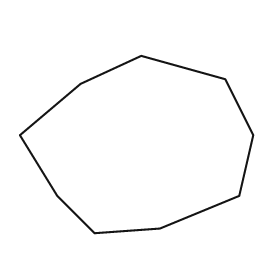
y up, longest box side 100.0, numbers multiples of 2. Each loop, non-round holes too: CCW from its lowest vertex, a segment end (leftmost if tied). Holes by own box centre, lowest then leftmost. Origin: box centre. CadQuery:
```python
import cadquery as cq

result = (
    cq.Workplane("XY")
    .moveTo(-18.0, -38.0)
    .lineTo(10.0, -36.0)
    .lineTo(44.0, -22.0)
    .lineTo(50.0, 4.0)
    .lineTo(38.0, 28.0)
    .lineTo(2.0, 38.0)
    .lineTo(-24.0, 26.0)
    .lineTo(-50.0, 4.0)
    .lineTo(-34.0, -22.0)
    .close()
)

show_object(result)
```